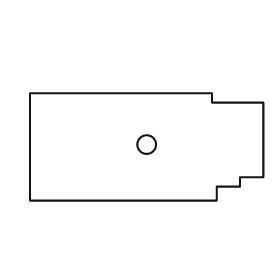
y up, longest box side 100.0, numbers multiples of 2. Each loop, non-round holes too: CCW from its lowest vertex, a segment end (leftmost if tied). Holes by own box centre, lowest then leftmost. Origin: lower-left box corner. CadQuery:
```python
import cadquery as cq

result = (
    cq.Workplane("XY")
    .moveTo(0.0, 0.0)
    .lineTo(80.0, 0.0)
    .lineTo(80.0, 6.0)
    .lineTo(90.0, 6.0)
    .lineTo(90.0, 10.0)
    .lineTo(100.0, 10.0)
    .lineTo(100.0, 42.0)
    .lineTo(78.0, 42.0)
    .lineTo(78.0, 46.0)
    .lineTo(0.0, 46.0)
    .close()
    .moveTo(50.0, 24.0)
    .circle(4.0)
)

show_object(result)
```